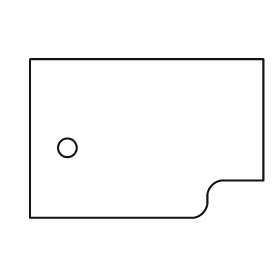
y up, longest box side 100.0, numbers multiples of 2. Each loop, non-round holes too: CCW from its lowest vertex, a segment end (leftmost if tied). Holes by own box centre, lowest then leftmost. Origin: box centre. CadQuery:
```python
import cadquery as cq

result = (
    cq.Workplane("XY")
    .moveTo(-50.0, -34.0)
    .lineTo(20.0, -34.0)
    .threePointArc((24.0, -32.0), (26.0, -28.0))
    .lineTo(26.0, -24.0)
    .threePointArc((28.0, -20.0), (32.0, -18.0))
    .lineTo(50.0, -18.0)
    .lineTo(50.0, 34.0)
    .lineTo(-50.0, 34.0)
    .close()
    .moveTo(-34.0, -4.0)
    .circle(4.0)
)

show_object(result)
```